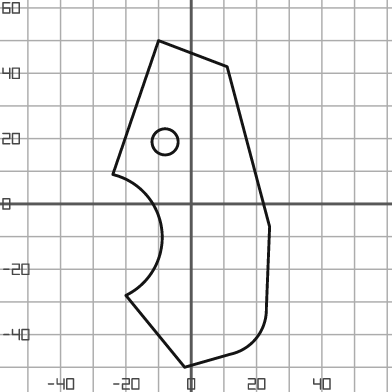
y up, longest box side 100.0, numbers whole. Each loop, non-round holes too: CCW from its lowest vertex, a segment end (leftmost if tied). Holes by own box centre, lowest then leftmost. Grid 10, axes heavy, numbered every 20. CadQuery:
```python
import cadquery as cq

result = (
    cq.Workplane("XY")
    .moveTo(-2.0, -50.0)
    .lineTo(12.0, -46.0)
    .threePointArc((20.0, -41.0), (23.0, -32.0))
    .lineTo(24.0, -7.0)
    .lineTo(11.0, 42.0)
    .lineTo(-10.0, 50.0)
    .lineTo(-24.0, 9.0)
    .threePointArc((-9.0, -8.0), (-20.0, -28.0))
    .close()
    .moveTo(-8.0, 19.0)
    .circle(4.0)
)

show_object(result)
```